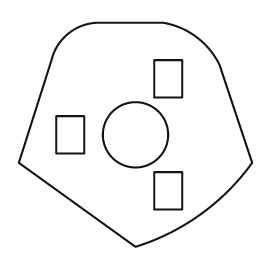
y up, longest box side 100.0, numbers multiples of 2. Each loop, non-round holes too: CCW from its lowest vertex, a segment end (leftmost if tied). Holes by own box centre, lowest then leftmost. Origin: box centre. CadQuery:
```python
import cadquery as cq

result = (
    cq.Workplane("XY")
    .moveTo(0.0, -48.0)
    .threePointArc((28.0, -34.0), (50.0, -12.0))
    .lineTo(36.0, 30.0)
    .threePointArc((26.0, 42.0), (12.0, 48.0))
    .lineTo(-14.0, 48.0)
    .threePointArc((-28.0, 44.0), (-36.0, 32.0))
    .lineTo(-50.0, -12.0)
    .close()
    .moveTo(8.0, -32.0)
    .lineTo(20.0, -32.0)
    .lineTo(20.0, -16.0)
    .lineTo(8.0, -16.0)
    .close()
    .moveTo(-34.0, -8.0)
    .lineTo(-22.0, -8.0)
    .lineTo(-22.0, 8.0)
    .lineTo(-34.0, 8.0)
    .close()
    .moveTo(0.0, 0.0)
    .circle(14.0)
    .moveTo(8.0, 16.0)
    .lineTo(20.0, 16.0)
    .lineTo(20.0, 32.0)
    .lineTo(8.0, 32.0)
    .close()
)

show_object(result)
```